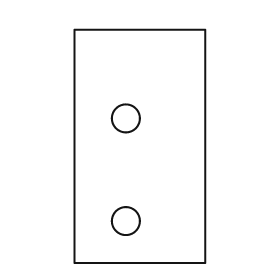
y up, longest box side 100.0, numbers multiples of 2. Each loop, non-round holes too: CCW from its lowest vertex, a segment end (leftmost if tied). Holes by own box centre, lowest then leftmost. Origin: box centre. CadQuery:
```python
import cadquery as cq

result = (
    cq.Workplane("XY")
    .moveTo(-28.0, -50.0)
    .lineTo(28.0, -50.0)
    .lineTo(28.0, 50.0)
    .lineTo(-28.0, 50.0)
    .close()
    .moveTo(-6.0, -32.0)
    .circle(6.0)
    .moveTo(-6.0, 12.0)
    .circle(6.0)
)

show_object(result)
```